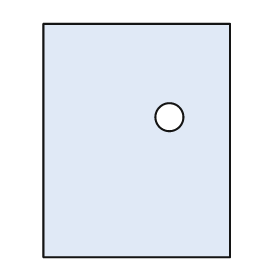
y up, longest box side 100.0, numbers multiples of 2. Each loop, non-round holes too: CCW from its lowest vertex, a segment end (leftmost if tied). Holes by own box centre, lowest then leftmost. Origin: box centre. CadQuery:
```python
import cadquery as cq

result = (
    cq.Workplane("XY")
    .moveTo(-40.0, -50.0)
    .lineTo(40.0, -50.0)
    .lineTo(40.0, 50.0)
    .lineTo(-40.0, 50.0)
    .close()
    .moveTo(14.0, 10.0)
    .circle(6.0)
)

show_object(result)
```